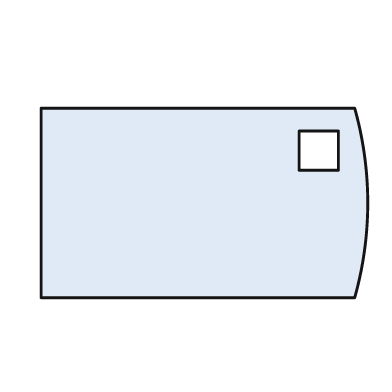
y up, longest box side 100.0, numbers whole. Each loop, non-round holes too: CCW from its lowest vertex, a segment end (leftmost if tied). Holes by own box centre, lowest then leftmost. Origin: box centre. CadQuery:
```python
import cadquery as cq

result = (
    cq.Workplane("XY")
    .moveTo(-50.0, -29.0)
    .lineTo(46.0, -29.0)
    .threePointArc((50.0, 0.0), (46.0, 29.0))
    .lineTo(-50.0, 29.0)
    .close()
    .moveTo(29.0, 10.0)
    .lineTo(41.0, 10.0)
    .lineTo(41.0, 22.0)
    .lineTo(29.0, 22.0)
    .close()
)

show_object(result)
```